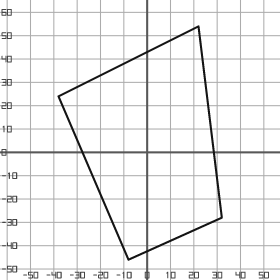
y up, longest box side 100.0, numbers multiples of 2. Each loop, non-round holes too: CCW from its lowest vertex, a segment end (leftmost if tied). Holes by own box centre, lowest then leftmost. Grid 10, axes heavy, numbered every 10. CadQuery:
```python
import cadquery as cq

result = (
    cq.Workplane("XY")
    .moveTo(-8.0, -46.0)
    .lineTo(32.0, -28.0)
    .lineTo(22.0, 54.0)
    .lineTo(-38.0, 24.0)
    .close()
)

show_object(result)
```